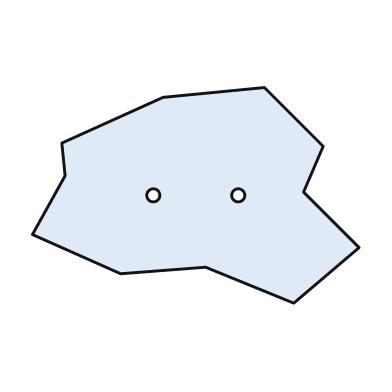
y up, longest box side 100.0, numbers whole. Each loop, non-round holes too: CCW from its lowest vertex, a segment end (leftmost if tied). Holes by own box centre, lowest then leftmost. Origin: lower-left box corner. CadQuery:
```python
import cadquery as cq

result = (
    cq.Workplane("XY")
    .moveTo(80.0, 0.0)
    .lineTo(100.0, 17.0)
    .lineTo(83.0, 34.0)
    .lineTo(89.0, 48.0)
    .lineTo(71.0, 66.0)
    .lineTo(40.0, 63.0)
    .lineTo(9.0, 49.0)
    .lineTo(10.0, 39.0)
    .lineTo(0.0, 21.0)
    .lineTo(27.0, 9.0)
    .lineTo(53.0, 11.0)
    .close()
    .moveTo(37.0, 33.0)
    .circle(2.0)
    .moveTo(63.0, 33.0)
    .circle(2.0)
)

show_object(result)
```